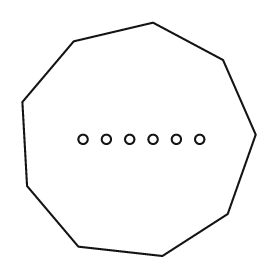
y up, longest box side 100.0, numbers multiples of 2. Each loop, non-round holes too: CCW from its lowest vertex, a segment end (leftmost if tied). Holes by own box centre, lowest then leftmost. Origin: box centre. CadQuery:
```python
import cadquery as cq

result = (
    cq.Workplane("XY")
    .moveTo(10.0, -50.0)
    .lineTo(38.0, -32.0)
    .lineTo(50.0, 2.0)
    .lineTo(36.0, 34.0)
    .lineTo(6.0, 50.0)
    .lineTo(-28.0, 42.0)
    .lineTo(-50.0, 16.0)
    .lineTo(-48.0, -20.0)
    .lineTo(-26.0, -46.0)
    .close()
    .moveTo(-24.0, 0.0)
    .circle(2.0)
    .moveTo(-14.0, 0.0)
    .circle(2.0)
    .moveTo(-4.0, 0.0)
    .circle(2.0)
    .moveTo(6.0, 0.0)
    .circle(2.0)
    .moveTo(16.0, 0.0)
    .circle(2.0)
    .moveTo(26.0, 0.0)
    .circle(2.0)
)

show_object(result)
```